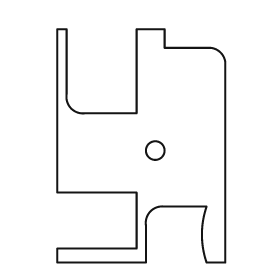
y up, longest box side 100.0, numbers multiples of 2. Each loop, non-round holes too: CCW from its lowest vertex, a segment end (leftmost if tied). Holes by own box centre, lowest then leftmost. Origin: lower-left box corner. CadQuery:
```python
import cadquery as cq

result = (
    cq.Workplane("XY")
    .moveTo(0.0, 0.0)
    .lineTo(38.0, 0.0)
    .lineTo(38.0, 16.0)
    .threePointArc((40.0, 22.0), (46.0, 24.0))
    .lineTo(64.0, 24.0)
    .threePointArc((62.0, 12.0), (64.0, 0.0))
    .lineTo(72.0, 0.0)
    .lineTo(72.0, 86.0)
    .threePointArc((70.0, 90.0), (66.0, 92.0))
    .lineTo(46.0, 92.0)
    .lineTo(46.0, 100.0)
    .lineTo(34.0, 100.0)
    .lineTo(34.0, 64.0)
    .lineTo(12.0, 64.0)
    .threePointArc((6.0, 66.0), (4.0, 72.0))
    .lineTo(4.0, 100.0)
    .lineTo(0.0, 100.0)
    .lineTo(0.0, 30.0)
    .lineTo(34.0, 30.0)
    .lineTo(34.0, 6.0)
    .lineTo(0.0, 6.0)
    .close()
    .moveTo(42.0, 48.0)
    .circle(4.0)
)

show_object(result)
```